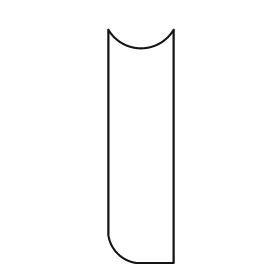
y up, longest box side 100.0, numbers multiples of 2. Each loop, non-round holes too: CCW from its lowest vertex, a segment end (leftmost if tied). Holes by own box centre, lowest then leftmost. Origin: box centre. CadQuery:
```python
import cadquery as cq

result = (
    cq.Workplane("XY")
    .moveTo(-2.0, -50.0)
    .lineTo(14.0, -50.0)
    .lineTo(14.0, 50.0)
    .threePointArc((0.0, 42.0), (-14.0, 50.0))
    .lineTo(-14.0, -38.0)
    .threePointArc((-10.0, -46.0), (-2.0, -50.0))
    .close()
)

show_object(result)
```